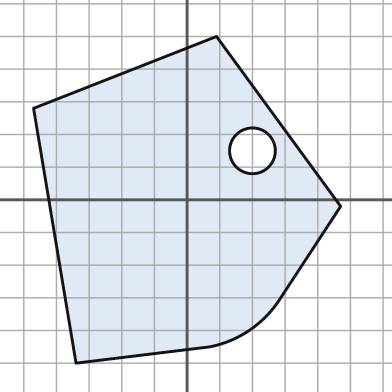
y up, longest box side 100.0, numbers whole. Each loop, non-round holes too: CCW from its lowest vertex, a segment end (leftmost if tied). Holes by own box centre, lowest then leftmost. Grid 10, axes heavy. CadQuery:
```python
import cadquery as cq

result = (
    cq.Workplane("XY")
    .moveTo(-34.0, -50.0)
    .lineTo(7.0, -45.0)
    .threePointArc((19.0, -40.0), (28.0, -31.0))
    .lineTo(47.0, -2.0)
    .lineTo(9.0, 50.0)
    .lineTo(-47.0, 28.0)
    .close()
    .moveTo(20.0, 15.0)
    .circle(7.0)
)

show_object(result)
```